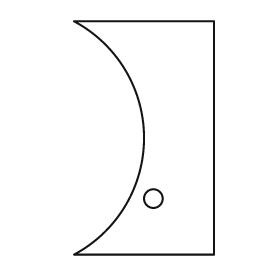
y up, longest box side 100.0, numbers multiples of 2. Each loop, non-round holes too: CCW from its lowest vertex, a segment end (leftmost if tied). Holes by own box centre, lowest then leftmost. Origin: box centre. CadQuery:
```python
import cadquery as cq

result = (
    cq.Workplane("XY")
    .moveTo(-30.0, -50.0)
    .lineTo(30.0, -50.0)
    .lineTo(30.0, 50.0)
    .lineTo(-30.0, 50.0)
    .threePointArc((0.0, 0.0), (-30.0, -50.0))
    .close()
    .moveTo(4.0, -26.0)
    .circle(4.0)
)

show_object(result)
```